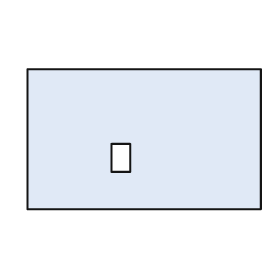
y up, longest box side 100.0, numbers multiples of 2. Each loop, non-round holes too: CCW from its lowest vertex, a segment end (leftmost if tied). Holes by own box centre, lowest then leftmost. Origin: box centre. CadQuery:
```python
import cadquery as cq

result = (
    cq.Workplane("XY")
    .moveTo(-50.0, -30.0)
    .lineTo(50.0, -30.0)
    .lineTo(50.0, 30.0)
    .lineTo(-50.0, 30.0)
    .close()
    .moveTo(-14.0, -14.0)
    .lineTo(-6.0, -14.0)
    .lineTo(-6.0, -2.0)
    .lineTo(-14.0, -2.0)
    .close()
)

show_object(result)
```